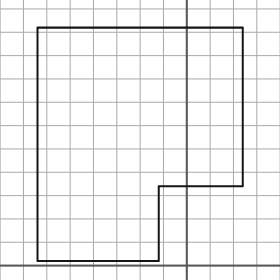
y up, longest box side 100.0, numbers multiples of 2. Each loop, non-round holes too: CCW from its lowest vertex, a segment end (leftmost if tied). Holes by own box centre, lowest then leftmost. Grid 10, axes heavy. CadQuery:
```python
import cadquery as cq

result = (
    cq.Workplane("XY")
    .moveTo(-64.0, 2.0)
    .lineTo(-12.0, 2.0)
    .lineTo(-12.0, 34.0)
    .lineTo(24.0, 34.0)
    .lineTo(24.0, 102.0)
    .lineTo(-64.0, 102.0)
    .close()
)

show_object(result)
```